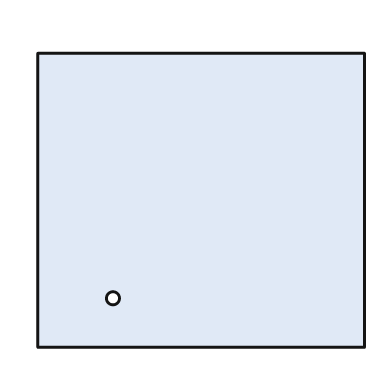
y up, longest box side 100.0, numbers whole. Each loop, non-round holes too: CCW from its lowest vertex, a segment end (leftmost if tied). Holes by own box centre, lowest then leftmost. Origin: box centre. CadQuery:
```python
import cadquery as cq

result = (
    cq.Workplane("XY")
    .moveTo(-50.0, -45.0)
    .lineTo(50.0, -45.0)
    .lineTo(50.0, 45.0)
    .lineTo(-50.0, 45.0)
    .close()
    .moveTo(-27.0, -30.0)
    .circle(2.0)
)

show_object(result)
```